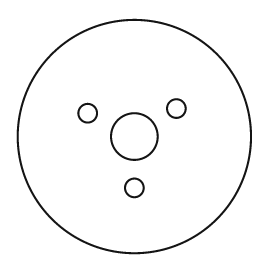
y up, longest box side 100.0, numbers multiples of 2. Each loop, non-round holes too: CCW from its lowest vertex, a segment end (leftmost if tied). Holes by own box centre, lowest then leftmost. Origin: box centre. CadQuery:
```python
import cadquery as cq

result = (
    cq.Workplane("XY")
    .moveTo(0.0, 0.0)
    .circle(50.0)
    .moveTo(0.0, -22.0)
    .circle(4.0)
    .moveTo(0.0, 0.0)
    .circle(10.0)
    .moveTo(-20.0, 10.0)
    .circle(4.0)
    .moveTo(18.0, 12.0)
    .circle(4.0)
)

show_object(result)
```